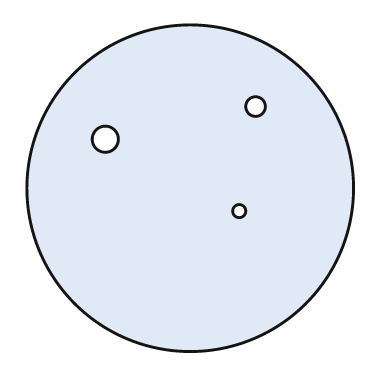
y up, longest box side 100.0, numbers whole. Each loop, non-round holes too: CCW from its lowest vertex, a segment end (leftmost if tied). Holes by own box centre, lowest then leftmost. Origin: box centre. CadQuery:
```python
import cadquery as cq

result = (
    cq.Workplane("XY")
    .moveTo(0.0, 0.0)
    .circle(50.0)
    .moveTo(15.0, -7.0)
    .circle(2.0)
    .moveTo(-26.0, 15.0)
    .circle(4.0)
    .moveTo(20.0, 25.0)
    .circle(3.0)
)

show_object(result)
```